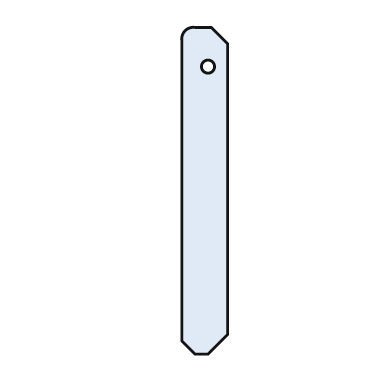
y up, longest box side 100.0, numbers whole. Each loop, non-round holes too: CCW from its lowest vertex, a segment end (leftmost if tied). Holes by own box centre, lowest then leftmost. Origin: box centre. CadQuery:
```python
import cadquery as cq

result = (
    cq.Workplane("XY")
    .moveTo(-3.0, -50.0)
    .lineTo(1.0, -50.0)
    .lineTo(7.0, -44.0)
    .lineTo(7.0, 45.0)
    .lineTo(2.0, 50.0)
    .lineTo(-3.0, 50.0)
    .threePointArc((-6.0, 49.0), (-7.0, 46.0))
    .lineTo(-7.0, -46.0)
    .close()
    .moveTo(1.0, 38.0)
    .circle(2.0)
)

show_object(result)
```